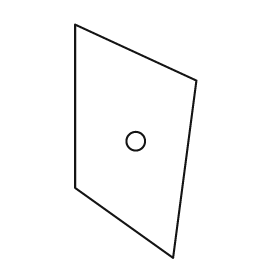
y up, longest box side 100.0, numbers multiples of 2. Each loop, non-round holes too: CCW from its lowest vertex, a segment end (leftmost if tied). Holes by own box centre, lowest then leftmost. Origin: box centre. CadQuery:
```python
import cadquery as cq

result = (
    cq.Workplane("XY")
    .moveTo(16.0, -50.0)
    .lineTo(26.0, 26.0)
    .lineTo(-26.0, 50.0)
    .lineTo(-26.0, -20.0)
    .close()
    .moveTo(0.0, 0.0)
    .circle(4.0)
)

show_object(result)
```